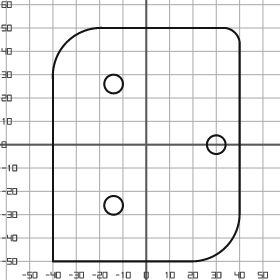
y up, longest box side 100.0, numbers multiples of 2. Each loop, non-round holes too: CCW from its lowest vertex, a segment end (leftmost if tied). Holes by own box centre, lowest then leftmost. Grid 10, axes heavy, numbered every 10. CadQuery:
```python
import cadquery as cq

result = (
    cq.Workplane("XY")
    .moveTo(-40.0, -50.0)
    .lineTo(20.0, -50.0)
    .threePointArc((34.0, -44.0), (40.0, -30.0))
    .lineTo(40.0, 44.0)
    .threePointArc((38.0, 48.0), (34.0, 50.0))
    .lineTo(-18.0, 50.0)
    .threePointArc((-34.0, 44.0), (-40.0, 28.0))
    .close()
    .moveTo(-14.0, -26.0)
    .circle(4.0)
    .moveTo(30.0, 0.0)
    .circle(4.0)
    .moveTo(-14.0, 26.0)
    .circle(4.0)
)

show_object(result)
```